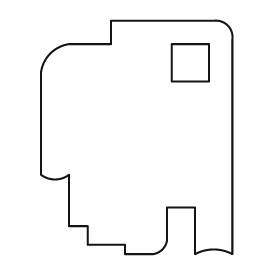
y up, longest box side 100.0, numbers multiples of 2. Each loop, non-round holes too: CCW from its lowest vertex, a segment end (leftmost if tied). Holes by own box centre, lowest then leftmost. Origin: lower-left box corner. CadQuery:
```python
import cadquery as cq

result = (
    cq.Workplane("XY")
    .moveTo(36.0, 0.0)
    .lineTo(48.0, 0.0)
    .threePointArc((52.0, 2.0), (54.0, 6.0))
    .lineTo(54.0, 20.0)
    .lineTo(66.0, 20.0)
    .lineTo(66.0, 0.0)
    .threePointArc((74.0, 2.0), (82.0, 0.0))
    .lineTo(82.0, 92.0)
    .threePointArc((80.0, 98.0), (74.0, 100.0))
    .lineTo(30.0, 100.0)
    .lineTo(30.0, 90.0)
    .lineTo(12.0, 90.0)
    .threePointArc((4.0, 86.0), (0.0, 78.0))
    .lineTo(0.0, 34.0)
    .threePointArc((6.0, 32.0), (12.0, 34.0))
    .lineTo(12.0, 12.0)
    .lineTo(20.0, 12.0)
    .lineTo(20.0, 4.0)
    .lineTo(36.0, 4.0)
    .close()
    .moveTo(56.0, 74.0)
    .lineTo(72.0, 74.0)
    .lineTo(72.0, 90.0)
    .lineTo(56.0, 90.0)
    .close()
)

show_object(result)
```